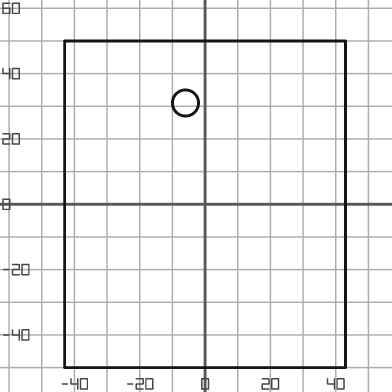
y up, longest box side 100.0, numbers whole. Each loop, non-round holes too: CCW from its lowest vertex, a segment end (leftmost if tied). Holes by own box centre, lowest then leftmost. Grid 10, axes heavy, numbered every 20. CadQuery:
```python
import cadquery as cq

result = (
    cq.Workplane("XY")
    .moveTo(-43.0, -50.0)
    .lineTo(43.0, -50.0)
    .lineTo(43.0, 50.0)
    .lineTo(-43.0, 50.0)
    .close()
    .moveTo(-6.0, 31.0)
    .circle(4.0)
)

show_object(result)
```